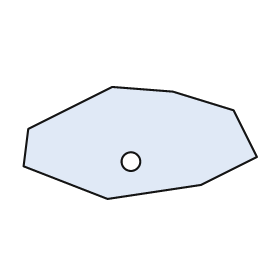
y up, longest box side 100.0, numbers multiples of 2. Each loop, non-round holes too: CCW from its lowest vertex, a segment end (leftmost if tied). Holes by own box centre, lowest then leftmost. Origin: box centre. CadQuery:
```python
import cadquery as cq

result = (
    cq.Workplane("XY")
    .moveTo(-14.0, -24.0)
    .lineTo(26.0, -18.0)
    .lineTo(50.0, -6.0)
    .lineTo(40.0, 14.0)
    .lineTo(14.0, 22.0)
    .lineTo(-12.0, 24.0)
    .lineTo(-48.0, 6.0)
    .lineTo(-50.0, -10.0)
    .close()
    .moveTo(-4.0, -8.0)
    .circle(4.0)
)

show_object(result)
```